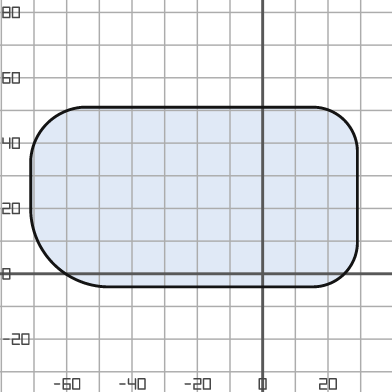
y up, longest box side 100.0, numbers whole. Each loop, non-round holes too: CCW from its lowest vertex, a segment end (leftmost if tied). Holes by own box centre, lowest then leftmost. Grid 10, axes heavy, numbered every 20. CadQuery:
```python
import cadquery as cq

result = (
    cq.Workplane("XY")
    .moveTo(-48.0, -4.0)
    .lineTo(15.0, -4.0)
    .threePointArc((25.0, 0.0), (29.0, 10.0))
    .lineTo(29.0, 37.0)
    .threePointArc((25.0, 47.0), (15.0, 51.0))
    .lineTo(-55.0, 51.0)
    .threePointArc((-66.0, 46.0), (-71.0, 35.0))
    .lineTo(-71.0, 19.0)
    .threePointArc((-64.0, 3.0), (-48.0, -4.0))
    .close()
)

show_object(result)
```